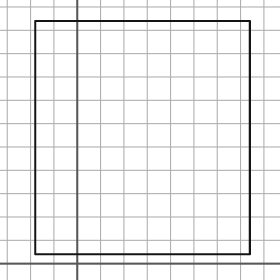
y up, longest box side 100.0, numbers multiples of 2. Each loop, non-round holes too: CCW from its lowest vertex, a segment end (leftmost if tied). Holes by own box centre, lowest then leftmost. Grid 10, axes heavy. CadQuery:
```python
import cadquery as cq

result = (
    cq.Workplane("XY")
    .moveTo(-18.0, 4.0)
    .lineTo(74.0, 4.0)
    .lineTo(74.0, 104.0)
    .lineTo(-18.0, 104.0)
    .close()
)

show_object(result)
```